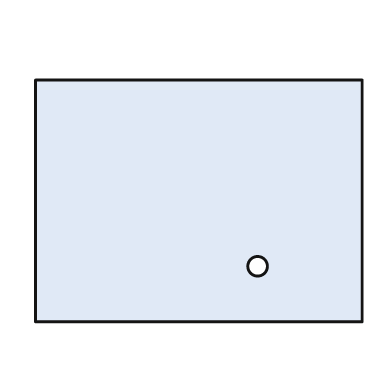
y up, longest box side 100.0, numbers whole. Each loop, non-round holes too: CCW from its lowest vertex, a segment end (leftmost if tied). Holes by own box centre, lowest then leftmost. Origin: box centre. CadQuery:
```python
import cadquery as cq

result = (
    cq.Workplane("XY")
    .moveTo(-50.0, -37.0)
    .lineTo(50.0, -37.0)
    .lineTo(50.0, 37.0)
    .lineTo(-50.0, 37.0)
    .close()
    .moveTo(18.0, -20.0)
    .circle(3.0)
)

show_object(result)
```